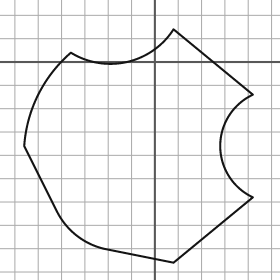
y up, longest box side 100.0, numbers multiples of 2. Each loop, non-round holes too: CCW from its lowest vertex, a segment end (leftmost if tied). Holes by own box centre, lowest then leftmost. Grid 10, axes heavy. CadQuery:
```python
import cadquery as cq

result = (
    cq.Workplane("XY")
    .moveTo(8.0, -86.0)
    .lineTo(42.0, -58.0)
    .threePointArc((28.0, -36.0), (42.0, -14.0))
    .lineTo(8.0, 14.0)
    .threePointArc((-12.0, 0.0), (-36.0, 4.0))
    .threePointArc((-50.0, -14.0), (-56.0, -36.0))
    .lineTo(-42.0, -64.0)
    .threePointArc((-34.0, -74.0), (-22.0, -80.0))
    .close()
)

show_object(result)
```